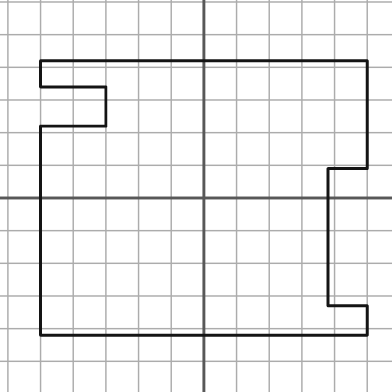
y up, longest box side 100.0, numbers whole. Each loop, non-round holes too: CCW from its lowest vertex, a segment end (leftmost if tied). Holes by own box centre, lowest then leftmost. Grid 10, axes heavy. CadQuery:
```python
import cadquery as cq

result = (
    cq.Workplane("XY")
    .moveTo(-50.0, -42.0)
    .lineTo(50.0, -42.0)
    .lineTo(50.0, -33.0)
    .lineTo(38.0, -33.0)
    .lineTo(38.0, 9.0)
    .lineTo(50.0, 9.0)
    .lineTo(50.0, 42.0)
    .lineTo(-50.0, 42.0)
    .lineTo(-50.0, 34.0)
    .lineTo(-30.0, 34.0)
    .lineTo(-30.0, 22.0)
    .lineTo(-50.0, 22.0)
    .close()
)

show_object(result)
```